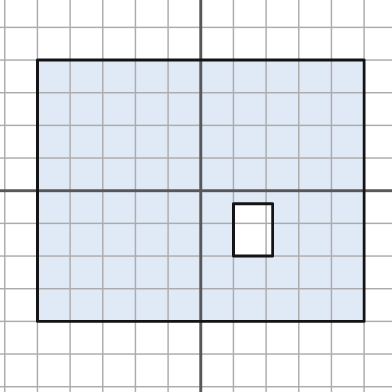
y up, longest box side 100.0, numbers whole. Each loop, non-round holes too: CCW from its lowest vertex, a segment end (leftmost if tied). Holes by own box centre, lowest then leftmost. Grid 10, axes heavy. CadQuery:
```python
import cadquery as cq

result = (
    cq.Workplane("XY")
    .moveTo(-50.0, -40.0)
    .lineTo(50.0, -40.0)
    .lineTo(50.0, 40.0)
    .lineTo(-50.0, 40.0)
    .close()
    .moveTo(10.0, -20.0)
    .lineTo(22.0, -20.0)
    .lineTo(22.0, -4.0)
    .lineTo(10.0, -4.0)
    .close()
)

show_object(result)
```